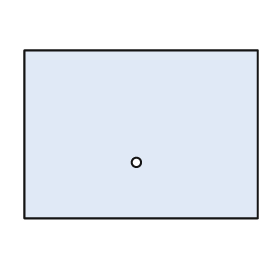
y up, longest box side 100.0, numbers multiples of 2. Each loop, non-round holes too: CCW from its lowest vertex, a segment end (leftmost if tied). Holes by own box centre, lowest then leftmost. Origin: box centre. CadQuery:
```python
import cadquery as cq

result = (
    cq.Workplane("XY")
    .moveTo(-50.0, -36.0)
    .lineTo(50.0, -36.0)
    .lineTo(50.0, 36.0)
    .lineTo(-50.0, 36.0)
    .close()
    .moveTo(-2.0, -12.0)
    .circle(2.0)
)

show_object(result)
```